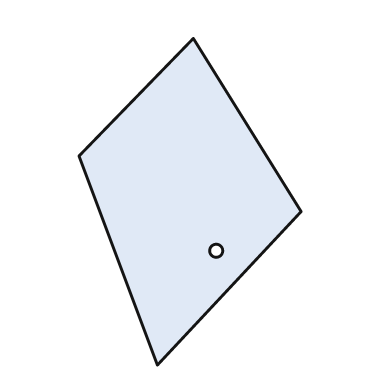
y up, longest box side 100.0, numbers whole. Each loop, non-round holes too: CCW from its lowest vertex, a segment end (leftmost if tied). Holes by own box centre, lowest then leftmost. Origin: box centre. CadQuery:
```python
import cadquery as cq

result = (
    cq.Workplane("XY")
    .moveTo(-10.0, -50.0)
    .lineTo(34.0, -3.0)
    .lineTo(1.0, 50.0)
    .lineTo(-34.0, 14.0)
    .close()
    .moveTo(8.0, -15.0)
    .circle(2.0)
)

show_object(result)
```